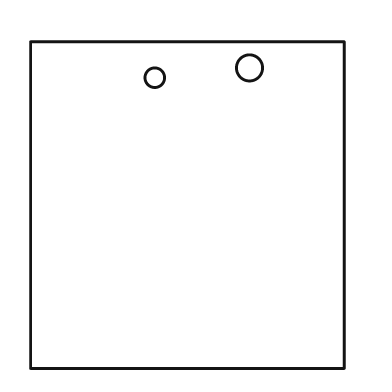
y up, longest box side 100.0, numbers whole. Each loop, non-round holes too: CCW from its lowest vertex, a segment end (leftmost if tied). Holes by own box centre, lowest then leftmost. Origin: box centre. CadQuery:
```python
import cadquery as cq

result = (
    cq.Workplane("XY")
    .moveTo(-48.0, -50.0)
    .lineTo(48.0, -50.0)
    .lineTo(48.0, 50.0)
    .lineTo(-48.0, 50.0)
    .close()
    .moveTo(-10.0, 39.0)
    .circle(3.0)
    .moveTo(19.0, 42.0)
    .circle(4.0)
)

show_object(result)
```